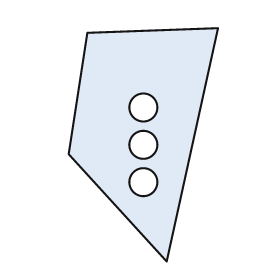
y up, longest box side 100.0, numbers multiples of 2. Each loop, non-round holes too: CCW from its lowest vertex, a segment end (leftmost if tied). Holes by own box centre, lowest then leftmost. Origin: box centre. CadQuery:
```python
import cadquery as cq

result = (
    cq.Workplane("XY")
    .moveTo(10.0, -50.0)
    .lineTo(32.0, 50.0)
    .lineTo(-24.0, 48.0)
    .lineTo(-32.0, -4.0)
    .close()
    .moveTo(0.0, -16.0)
    .circle(6.0)
    .moveTo(0.0, 0.0)
    .circle(6.0)
    .moveTo(0.0, 16.0)
    .circle(6.0)
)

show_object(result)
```